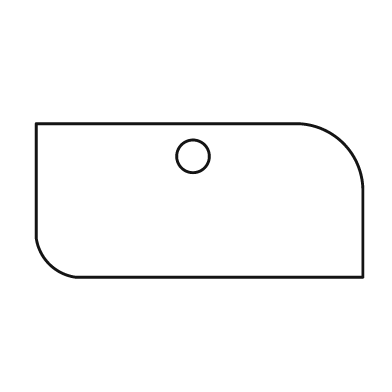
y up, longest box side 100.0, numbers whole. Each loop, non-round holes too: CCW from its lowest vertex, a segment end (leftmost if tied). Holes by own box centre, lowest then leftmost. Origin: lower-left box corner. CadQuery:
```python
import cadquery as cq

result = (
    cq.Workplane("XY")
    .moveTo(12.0, 0.0)
    .lineTo(100.0, 0.0)
    .lineTo(100.0, 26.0)
    .threePointArc((94.0, 41.0), (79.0, 47.0))
    .lineTo(0.0, 47.0)
    .lineTo(0.0, 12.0)
    .threePointArc((4.0, 4.0), (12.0, 0.0))
    .close()
    .moveTo(48.0, 37.0)
    .circle(5.0)
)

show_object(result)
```